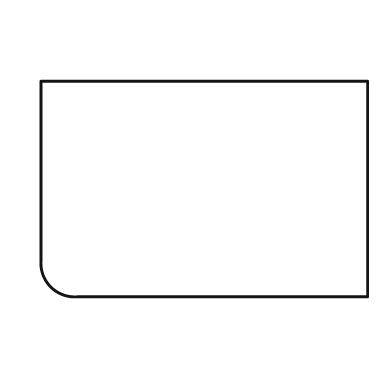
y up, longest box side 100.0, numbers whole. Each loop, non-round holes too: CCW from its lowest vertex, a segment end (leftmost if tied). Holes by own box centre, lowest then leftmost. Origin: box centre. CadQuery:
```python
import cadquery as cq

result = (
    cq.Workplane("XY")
    .moveTo(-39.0, -33.0)
    .lineTo(50.0, -33.0)
    .lineTo(50.0, 33.0)
    .lineTo(-50.0, 33.0)
    .lineTo(-50.0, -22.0)
    .threePointArc((-47.0, -30.0), (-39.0, -33.0))
    .close()
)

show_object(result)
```